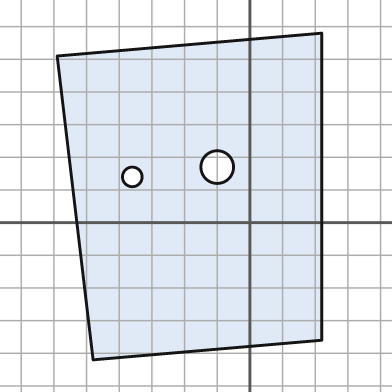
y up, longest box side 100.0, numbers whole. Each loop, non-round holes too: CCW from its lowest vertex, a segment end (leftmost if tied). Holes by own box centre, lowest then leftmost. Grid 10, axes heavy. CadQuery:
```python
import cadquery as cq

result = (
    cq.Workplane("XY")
    .moveTo(-48.0, -42.0)
    .lineTo(22.0, -36.0)
    .lineTo(22.0, 58.0)
    .lineTo(-59.0, 51.0)
    .close()
    .moveTo(-36.0, 14.0)
    .circle(3.0)
    .moveTo(-10.0, 17.0)
    .circle(5.0)
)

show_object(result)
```